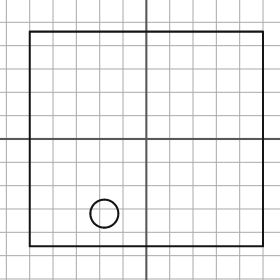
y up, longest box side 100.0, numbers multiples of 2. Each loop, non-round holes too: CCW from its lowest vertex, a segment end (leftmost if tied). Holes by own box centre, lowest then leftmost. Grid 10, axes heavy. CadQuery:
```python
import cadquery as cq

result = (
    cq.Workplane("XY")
    .moveTo(-50.0, -46.0)
    .lineTo(50.0, -46.0)
    .lineTo(50.0, 46.0)
    .lineTo(-50.0, 46.0)
    .close()
    .moveTo(-18.0, -32.0)
    .circle(6.0)
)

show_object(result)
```